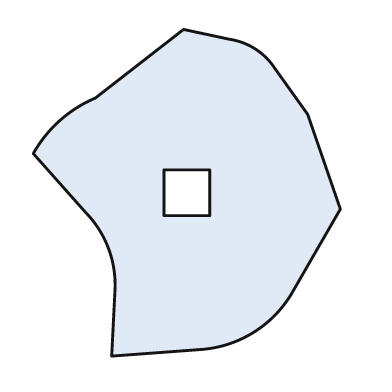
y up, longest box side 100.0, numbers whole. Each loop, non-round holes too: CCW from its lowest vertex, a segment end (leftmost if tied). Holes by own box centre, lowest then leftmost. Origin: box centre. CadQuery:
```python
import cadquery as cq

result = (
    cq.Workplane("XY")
    .moveTo(-23.0, -50.0)
    .lineTo(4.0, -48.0)
    .threePointArc((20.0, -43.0), (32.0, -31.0))
    .lineTo(47.0, -5.0)
    .lineTo(37.0, 24.0)
    .lineTo(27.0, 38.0)
    .threePointArc((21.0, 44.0), (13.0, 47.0))
    .lineTo(-1.0, 50.0)
    .lineTo(-28.0, 29.0)
    .threePointArc((-39.0, 22.0), (-47.0, 12.0))
    .lineTo(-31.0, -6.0)
    .threePointArc((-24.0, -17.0), (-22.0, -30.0))
    .close()
    .moveTo(-7.0, -7.0)
    .lineTo(7.0, -7.0)
    .lineTo(7.0, 7.0)
    .lineTo(-7.0, 7.0)
    .close()
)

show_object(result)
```